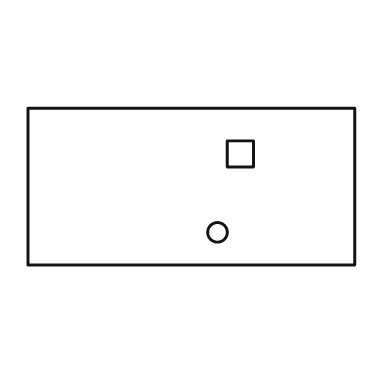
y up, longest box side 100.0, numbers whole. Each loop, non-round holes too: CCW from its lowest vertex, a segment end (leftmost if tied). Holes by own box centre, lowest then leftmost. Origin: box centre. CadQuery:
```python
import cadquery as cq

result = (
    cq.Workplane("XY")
    .moveTo(-50.0, -24.0)
    .lineTo(50.0, -24.0)
    .lineTo(50.0, 24.0)
    .lineTo(-50.0, 24.0)
    .close()
    .moveTo(8.0, -14.0)
    .circle(3.0)
    .moveTo(11.0, 6.0)
    .lineTo(19.0, 6.0)
    .lineTo(19.0, 14.0)
    .lineTo(11.0, 14.0)
    .close()
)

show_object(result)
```